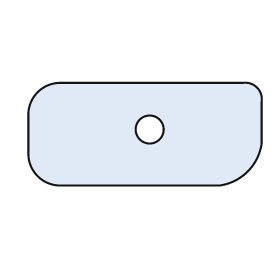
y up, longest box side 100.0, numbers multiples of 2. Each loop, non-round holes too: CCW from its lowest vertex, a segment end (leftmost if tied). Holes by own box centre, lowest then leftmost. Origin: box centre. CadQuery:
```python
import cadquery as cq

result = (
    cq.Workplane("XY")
    .moveTo(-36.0, -22.0)
    .lineTo(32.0, -22.0)
    .threePointArc((44.0, -16.0), (50.0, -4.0))
    .lineTo(50.0, 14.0)
    .threePointArc((48.0, 20.0), (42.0, 22.0))
    .lineTo(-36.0, 22.0)
    .threePointArc((-46.0, 18.0), (-50.0, 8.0))
    .lineTo(-50.0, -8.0)
    .threePointArc((-46.0, -18.0), (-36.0, -22.0))
    .close()
    .moveTo(2.0, 2.0)
    .circle(6.0)
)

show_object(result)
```